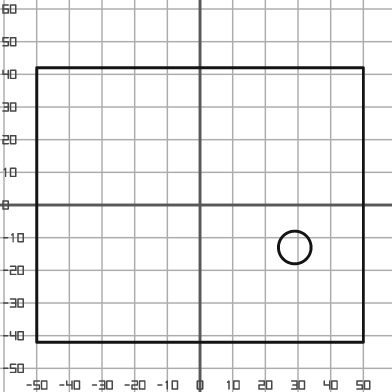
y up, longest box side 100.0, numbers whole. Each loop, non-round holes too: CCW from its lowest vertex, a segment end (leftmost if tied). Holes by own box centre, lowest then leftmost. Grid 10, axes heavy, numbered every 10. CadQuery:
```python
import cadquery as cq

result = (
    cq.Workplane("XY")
    .moveTo(-50.0, -42.0)
    .lineTo(50.0, -42.0)
    .lineTo(50.0, 42.0)
    .lineTo(-50.0, 42.0)
    .close()
    .moveTo(29.0, -13.0)
    .circle(5.0)
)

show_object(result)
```